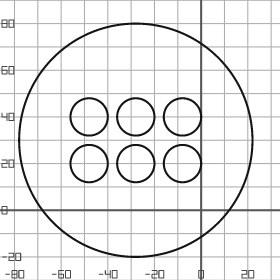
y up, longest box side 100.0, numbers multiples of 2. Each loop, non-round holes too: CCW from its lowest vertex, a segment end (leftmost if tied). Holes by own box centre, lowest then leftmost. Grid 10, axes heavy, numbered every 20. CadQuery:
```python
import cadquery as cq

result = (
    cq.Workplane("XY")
    .moveTo(-28.0, 30.0)
    .circle(50.0)
    .moveTo(-48.0, 20.0)
    .circle(8.0)
    .moveTo(-28.0, 20.0)
    .circle(8.0)
    .moveTo(-8.0, 20.0)
    .circle(8.0)
    .moveTo(-48.0, 40.0)
    .circle(8.0)
    .moveTo(-28.0, 40.0)
    .circle(8.0)
    .moveTo(-8.0, 40.0)
    .circle(8.0)
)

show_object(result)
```